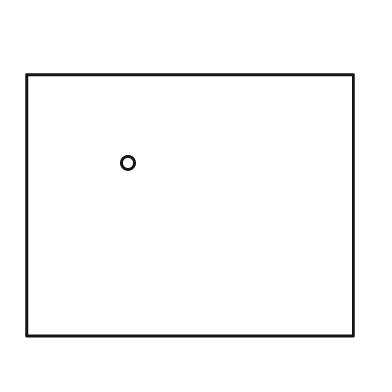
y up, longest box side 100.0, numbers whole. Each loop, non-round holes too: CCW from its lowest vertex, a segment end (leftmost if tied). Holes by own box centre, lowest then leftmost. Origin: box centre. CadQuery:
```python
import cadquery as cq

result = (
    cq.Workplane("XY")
    .moveTo(-50.0, -40.0)
    .lineTo(50.0, -40.0)
    .lineTo(50.0, 40.0)
    .lineTo(-50.0, 40.0)
    .close()
    .moveTo(-19.0, 13.0)
    .circle(2.0)
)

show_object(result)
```